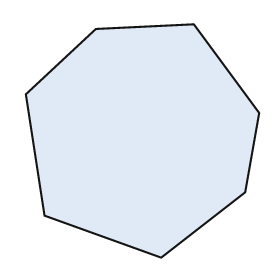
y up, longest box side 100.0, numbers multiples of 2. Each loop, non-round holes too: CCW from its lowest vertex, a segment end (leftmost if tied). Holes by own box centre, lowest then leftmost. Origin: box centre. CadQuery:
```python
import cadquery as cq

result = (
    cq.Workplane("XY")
    .moveTo(8.0, -50.0)
    .lineTo(44.0, -22.0)
    .lineTo(50.0, 12.0)
    .lineTo(22.0, 50.0)
    .lineTo(-20.0, 48.0)
    .lineTo(-50.0, 20.0)
    .lineTo(-42.0, -32.0)
    .close()
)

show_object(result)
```